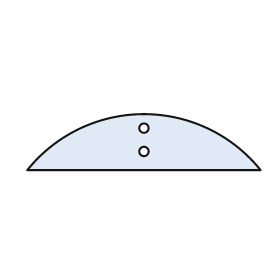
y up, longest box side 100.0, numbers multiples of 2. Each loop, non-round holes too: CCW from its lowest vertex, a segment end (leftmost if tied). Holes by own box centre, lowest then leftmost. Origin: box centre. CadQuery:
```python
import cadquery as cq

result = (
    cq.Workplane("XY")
    .moveTo(-50.0, -12.0)
    .lineTo(50.0, -12.0)
    .threePointArc((0.0, 12.0), (-50.0, -12.0))
    .close()
    .moveTo(0.0, -4.0)
    .circle(2.0)
    .moveTo(0.0, 6.0)
    .circle(2.0)
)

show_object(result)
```